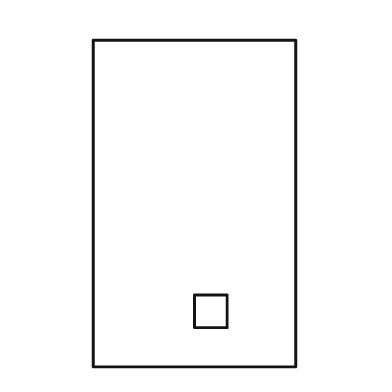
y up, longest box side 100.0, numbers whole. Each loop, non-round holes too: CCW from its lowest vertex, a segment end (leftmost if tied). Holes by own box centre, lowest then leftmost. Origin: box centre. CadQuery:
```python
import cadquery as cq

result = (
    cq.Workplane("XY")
    .moveTo(-31.0, -50.0)
    .lineTo(31.0, -50.0)
    .lineTo(31.0, 50.0)
    .lineTo(-31.0, 50.0)
    .close()
    .moveTo(0.0, -38.0)
    .lineTo(10.0, -38.0)
    .lineTo(10.0, -28.0)
    .lineTo(0.0, -28.0)
    .close()
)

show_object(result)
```